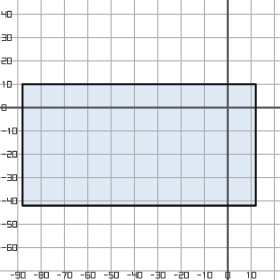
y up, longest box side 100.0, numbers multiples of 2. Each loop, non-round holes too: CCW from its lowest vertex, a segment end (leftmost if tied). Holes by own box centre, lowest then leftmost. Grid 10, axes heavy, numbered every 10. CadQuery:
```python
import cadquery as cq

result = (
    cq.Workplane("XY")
    .moveTo(-88.0, -42.0)
    .lineTo(12.0, -42.0)
    .lineTo(12.0, 10.0)
    .lineTo(-88.0, 10.0)
    .close()
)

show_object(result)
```